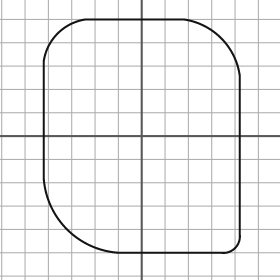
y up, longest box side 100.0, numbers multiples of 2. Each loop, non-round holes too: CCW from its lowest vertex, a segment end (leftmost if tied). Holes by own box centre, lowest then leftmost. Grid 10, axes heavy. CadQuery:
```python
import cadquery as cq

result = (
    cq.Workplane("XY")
    .moveTo(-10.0, -50.0)
    .lineTo(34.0, -50.0)
    .threePointArc((40.0, -48.0), (42.0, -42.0))
    .lineTo(42.0, 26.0)
    .threePointArc((34.0, 42.0), (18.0, 50.0))
    .lineTo(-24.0, 50.0)
    .threePointArc((-36.0, 44.0), (-42.0, 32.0))
    .lineTo(-42.0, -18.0)
    .threePointArc((-32.0, -40.0), (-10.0, -50.0))
    .close()
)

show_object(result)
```